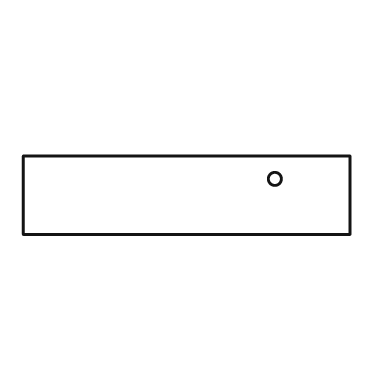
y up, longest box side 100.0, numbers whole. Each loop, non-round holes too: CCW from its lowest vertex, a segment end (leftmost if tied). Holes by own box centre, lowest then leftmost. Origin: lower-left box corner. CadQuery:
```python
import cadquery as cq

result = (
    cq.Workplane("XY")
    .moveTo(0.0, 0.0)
    .lineTo(100.0, 0.0)
    .lineTo(100.0, 24.0)
    .lineTo(0.0, 24.0)
    .close()
    .moveTo(77.0, 17.0)
    .circle(2.0)
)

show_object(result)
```